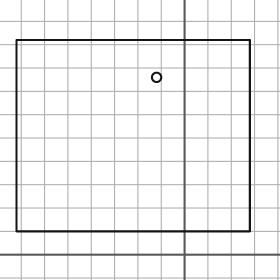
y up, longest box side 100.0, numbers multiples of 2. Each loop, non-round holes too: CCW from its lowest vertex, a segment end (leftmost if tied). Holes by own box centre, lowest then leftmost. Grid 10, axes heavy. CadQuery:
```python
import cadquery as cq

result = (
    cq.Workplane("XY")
    .moveTo(-72.0, 10.0)
    .lineTo(28.0, 10.0)
    .lineTo(28.0, 92.0)
    .lineTo(-72.0, 92.0)
    .close()
    .moveTo(-12.0, 76.0)
    .circle(2.0)
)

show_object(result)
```